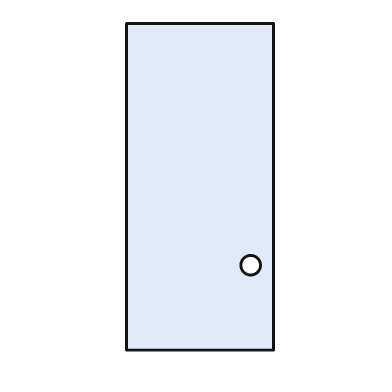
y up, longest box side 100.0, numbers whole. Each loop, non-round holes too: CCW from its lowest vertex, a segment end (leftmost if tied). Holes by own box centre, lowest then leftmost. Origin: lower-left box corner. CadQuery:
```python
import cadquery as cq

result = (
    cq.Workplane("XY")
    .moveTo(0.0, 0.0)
    .lineTo(45.0, 0.0)
    .lineTo(45.0, 100.0)
    .lineTo(0.0, 100.0)
    .close()
    .moveTo(38.0, 26.0)
    .circle(3.0)
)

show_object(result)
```